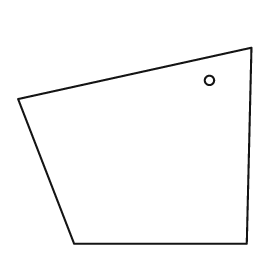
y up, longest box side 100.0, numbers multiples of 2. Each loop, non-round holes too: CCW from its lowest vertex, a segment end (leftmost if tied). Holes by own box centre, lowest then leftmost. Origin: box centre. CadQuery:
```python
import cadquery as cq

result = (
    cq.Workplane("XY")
    .moveTo(-26.0, -42.0)
    .lineTo(48.0, -42.0)
    .lineTo(50.0, 42.0)
    .lineTo(-50.0, 20.0)
    .close()
    .moveTo(32.0, 28.0)
    .circle(2.0)
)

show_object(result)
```